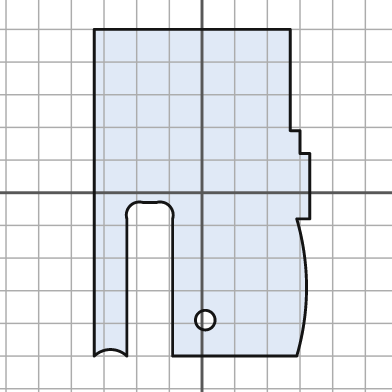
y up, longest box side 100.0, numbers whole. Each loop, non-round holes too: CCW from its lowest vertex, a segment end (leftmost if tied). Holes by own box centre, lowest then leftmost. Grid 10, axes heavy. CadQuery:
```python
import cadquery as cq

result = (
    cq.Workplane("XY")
    .moveTo(-33.0, -50.0)
    .threePointArc((-28.0, -48.0), (-23.0, -50.0))
    .lineTo(-23.0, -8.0)
    .threePointArc((-22.0, -4.0), (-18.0, -3.0))
    .lineTo(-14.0, -3.0)
    .threePointArc((-10.0, -4.0), (-9.0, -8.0))
    .lineTo(-9.0, -50.0)
    .lineTo(29.0, -50.0)
    .threePointArc((32.0, -29.0), (29.0, -8.0))
    .lineTo(33.0, -8.0)
    .lineTo(33.0, 12.0)
    .lineTo(30.0, 12.0)
    .lineTo(30.0, 19.0)
    .lineTo(27.0, 19.0)
    .lineTo(27.0, 50.0)
    .lineTo(-33.0, 50.0)
    .close()
    .moveTo(1.0, -39.0)
    .circle(3.0)
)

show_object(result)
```